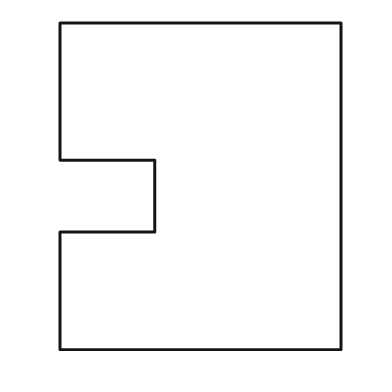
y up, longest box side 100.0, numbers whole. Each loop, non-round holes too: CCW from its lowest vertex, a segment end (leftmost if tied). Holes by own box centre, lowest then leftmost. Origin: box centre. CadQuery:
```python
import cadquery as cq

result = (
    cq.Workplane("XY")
    .moveTo(-43.0, -50.0)
    .lineTo(43.0, -50.0)
    .lineTo(43.0, 50.0)
    .lineTo(-43.0, 50.0)
    .lineTo(-43.0, 8.0)
    .lineTo(-14.0, 8.0)
    .lineTo(-14.0, -14.0)
    .lineTo(-43.0, -14.0)
    .close()
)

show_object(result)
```